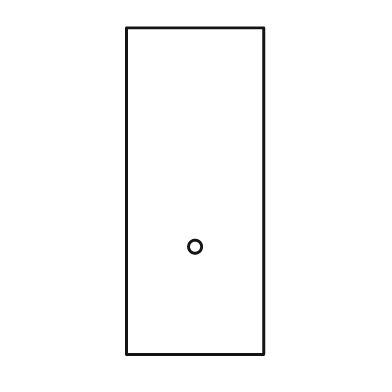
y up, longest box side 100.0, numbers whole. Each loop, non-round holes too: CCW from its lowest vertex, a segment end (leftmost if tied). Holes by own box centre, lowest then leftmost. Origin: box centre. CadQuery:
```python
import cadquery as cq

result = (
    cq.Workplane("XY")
    .moveTo(-21.0, -50.0)
    .lineTo(21.0, -50.0)
    .lineTo(21.0, 50.0)
    .lineTo(-21.0, 50.0)
    .close()
    .moveTo(0.0, -17.0)
    .circle(2.0)
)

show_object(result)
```